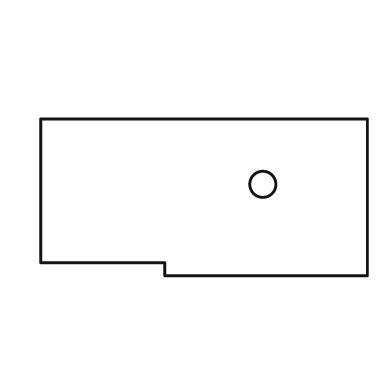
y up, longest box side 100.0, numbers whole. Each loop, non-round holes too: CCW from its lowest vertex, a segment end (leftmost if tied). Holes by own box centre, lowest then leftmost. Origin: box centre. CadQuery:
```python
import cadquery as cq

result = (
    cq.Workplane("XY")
    .moveTo(-12.0, -24.0)
    .lineTo(50.0, -24.0)
    .lineTo(50.0, 24.0)
    .lineTo(-50.0, 24.0)
    .lineTo(-50.0, -20.0)
    .lineTo(-12.0, -20.0)
    .close()
    .moveTo(18.0, 4.0)
    .circle(4.0)
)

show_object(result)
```